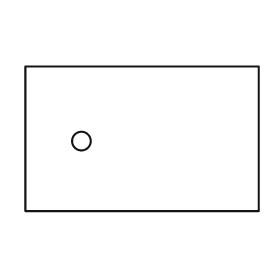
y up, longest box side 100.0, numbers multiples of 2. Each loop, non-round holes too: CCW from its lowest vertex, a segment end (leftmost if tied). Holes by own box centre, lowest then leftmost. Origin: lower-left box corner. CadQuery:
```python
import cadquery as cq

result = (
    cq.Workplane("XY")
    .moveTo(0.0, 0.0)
    .lineTo(100.0, 0.0)
    .lineTo(100.0, 62.0)
    .lineTo(0.0, 62.0)
    .close()
    .moveTo(24.0, 30.0)
    .circle(4.0)
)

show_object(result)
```